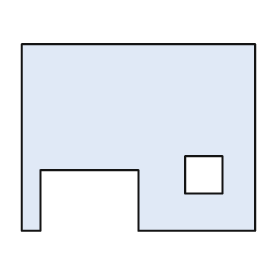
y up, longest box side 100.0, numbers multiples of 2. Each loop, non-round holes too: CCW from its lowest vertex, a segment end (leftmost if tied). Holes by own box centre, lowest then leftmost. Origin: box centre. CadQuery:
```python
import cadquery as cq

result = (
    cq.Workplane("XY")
    .moveTo(-50.0, -40.0)
    .lineTo(-42.0, -40.0)
    .lineTo(-42.0, -14.0)
    .lineTo(0.0, -14.0)
    .lineTo(0.0, -40.0)
    .lineTo(50.0, -40.0)
    .lineTo(50.0, 40.0)
    .lineTo(-50.0, 40.0)
    .close()
    .moveTo(20.0, -24.0)
    .lineTo(36.0, -24.0)
    .lineTo(36.0, -8.0)
    .lineTo(20.0, -8.0)
    .close()
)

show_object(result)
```